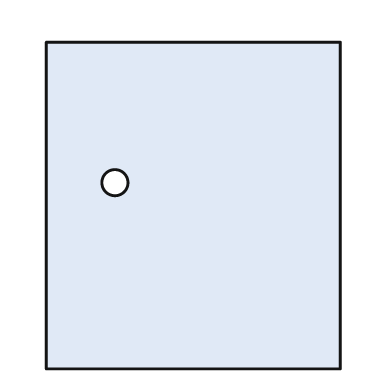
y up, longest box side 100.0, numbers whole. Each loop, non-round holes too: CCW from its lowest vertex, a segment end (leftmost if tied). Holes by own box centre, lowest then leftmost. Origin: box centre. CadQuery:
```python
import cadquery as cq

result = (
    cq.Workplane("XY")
    .moveTo(-45.0, -50.0)
    .lineTo(45.0, -50.0)
    .lineTo(45.0, 50.0)
    .lineTo(-45.0, 50.0)
    .close()
    .moveTo(-24.0, 7.0)
    .circle(4.0)
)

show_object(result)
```